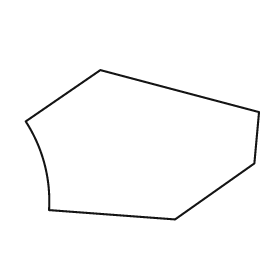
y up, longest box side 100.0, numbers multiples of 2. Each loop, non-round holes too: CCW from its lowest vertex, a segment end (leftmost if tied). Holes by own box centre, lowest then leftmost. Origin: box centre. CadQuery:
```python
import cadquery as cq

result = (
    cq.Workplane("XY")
    .moveTo(14.0, -32.0)
    .lineTo(48.0, -8.0)
    .lineTo(50.0, 14.0)
    .lineTo(-18.0, 32.0)
    .lineTo(-50.0, 10.0)
    .threePointArc((-42.0, -8.0), (-40.0, -28.0))
    .close()
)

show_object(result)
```